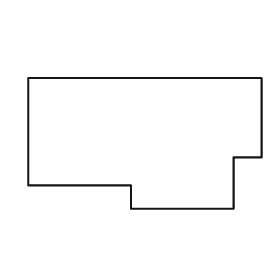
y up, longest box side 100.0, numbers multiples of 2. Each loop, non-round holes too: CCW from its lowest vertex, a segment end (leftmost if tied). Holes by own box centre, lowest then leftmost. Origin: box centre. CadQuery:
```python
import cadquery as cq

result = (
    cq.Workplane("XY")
    .moveTo(-6.0, -28.0)
    .lineTo(38.0, -28.0)
    .lineTo(38.0, -6.0)
    .lineTo(50.0, -6.0)
    .lineTo(50.0, 28.0)
    .lineTo(-50.0, 28.0)
    .lineTo(-50.0, -18.0)
    .lineTo(-6.0, -18.0)
    .close()
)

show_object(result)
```